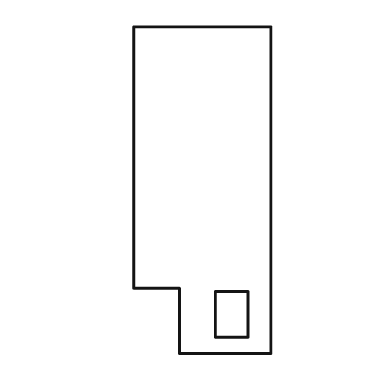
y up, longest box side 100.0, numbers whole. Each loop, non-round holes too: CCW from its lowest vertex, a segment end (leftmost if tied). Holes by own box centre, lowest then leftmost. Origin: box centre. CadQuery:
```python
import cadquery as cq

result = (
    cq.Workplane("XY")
    .moveTo(-7.0, -50.0)
    .lineTo(21.0, -50.0)
    .lineTo(21.0, 50.0)
    .lineTo(-21.0, 50.0)
    .lineTo(-21.0, -30.0)
    .lineTo(-7.0, -30.0)
    .close()
    .moveTo(4.0, -45.0)
    .lineTo(14.0, -45.0)
    .lineTo(14.0, -31.0)
    .lineTo(4.0, -31.0)
    .close()
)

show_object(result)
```